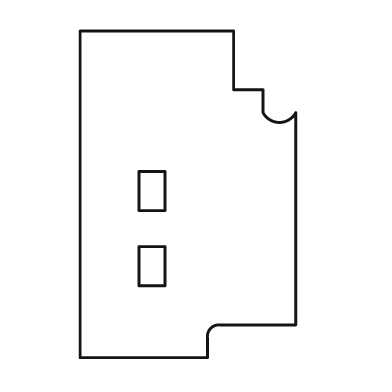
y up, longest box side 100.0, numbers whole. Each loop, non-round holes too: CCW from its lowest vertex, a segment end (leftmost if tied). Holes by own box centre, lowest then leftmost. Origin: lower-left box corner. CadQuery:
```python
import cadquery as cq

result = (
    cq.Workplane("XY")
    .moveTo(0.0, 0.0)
    .lineTo(39.0, 0.0)
    .lineTo(39.0, 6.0)
    .threePointArc((40.0, 9.0), (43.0, 10.0))
    .lineTo(66.0, 10.0)
    .lineTo(66.0, 75.0)
    .threePointArc((61.0, 72.0), (56.0, 75.0))
    .lineTo(56.0, 82.0)
    .lineTo(47.0, 82.0)
    .lineTo(47.0, 100.0)
    .lineTo(0.0, 100.0)
    .close()
    .moveTo(18.0, 22.0)
    .lineTo(26.0, 22.0)
    .lineTo(26.0, 34.0)
    .lineTo(18.0, 34.0)
    .close()
    .moveTo(18.0, 45.0)
    .lineTo(26.0, 45.0)
    .lineTo(26.0, 57.0)
    .lineTo(18.0, 57.0)
    .close()
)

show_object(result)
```